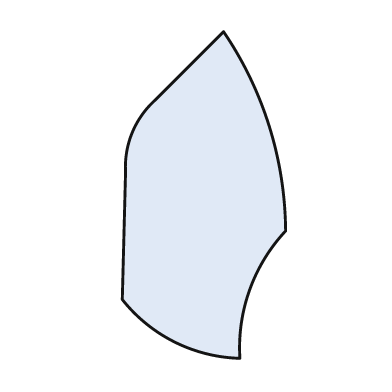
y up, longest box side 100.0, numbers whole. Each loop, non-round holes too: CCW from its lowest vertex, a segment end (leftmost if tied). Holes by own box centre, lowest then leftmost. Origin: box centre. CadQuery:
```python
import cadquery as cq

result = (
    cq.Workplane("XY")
    .moveTo(11.0, -50.0)
    .threePointArc((14.0, -29.0), (25.0, -11.0))
    .threePointArc((20.0, 21.0), (6.0, 50.0))
    .lineTo(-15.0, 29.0)
    .threePointArc((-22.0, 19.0), (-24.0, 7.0))
    .lineTo(-25.0, -32.0)
    .threePointArc((-9.0, -45.0), (11.0, -50.0))
    .close()
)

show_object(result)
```